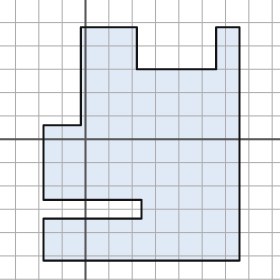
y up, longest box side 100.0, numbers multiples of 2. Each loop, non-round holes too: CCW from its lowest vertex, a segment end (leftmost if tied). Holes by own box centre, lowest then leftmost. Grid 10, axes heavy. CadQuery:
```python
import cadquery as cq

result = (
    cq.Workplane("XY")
    .moveTo(-18.0, -52.0)
    .lineTo(66.0, -52.0)
    .lineTo(66.0, 48.0)
    .lineTo(56.0, 48.0)
    .lineTo(56.0, 30.0)
    .lineTo(22.0, 30.0)
    .lineTo(22.0, 48.0)
    .lineTo(-2.0, 48.0)
    .lineTo(-2.0, 6.0)
    .lineTo(-18.0, 6.0)
    .lineTo(-18.0, -26.0)
    .lineTo(24.0, -26.0)
    .lineTo(24.0, -34.0)
    .lineTo(-18.0, -34.0)
    .close()
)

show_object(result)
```